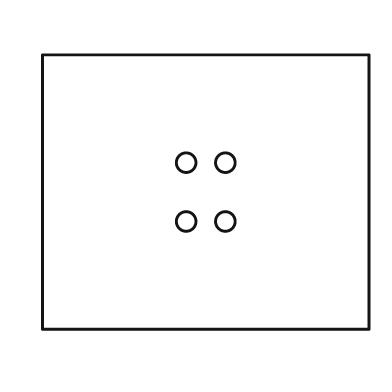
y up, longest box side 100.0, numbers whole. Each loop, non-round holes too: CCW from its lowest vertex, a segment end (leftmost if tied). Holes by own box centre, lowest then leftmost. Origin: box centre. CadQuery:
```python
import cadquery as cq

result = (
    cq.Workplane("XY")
    .moveTo(-50.0, -42.0)
    .lineTo(50.0, -42.0)
    .lineTo(50.0, 42.0)
    .lineTo(-50.0, 42.0)
    .close()
    .moveTo(-6.0, -9.0)
    .circle(3.0)
    .moveTo(6.0, -9.0)
    .circle(3.0)
    .moveTo(-6.0, 9.0)
    .circle(3.0)
    .moveTo(6.0, 9.0)
    .circle(3.0)
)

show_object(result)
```